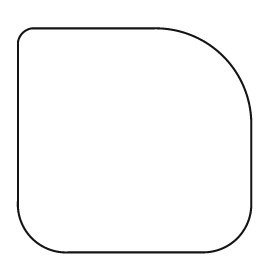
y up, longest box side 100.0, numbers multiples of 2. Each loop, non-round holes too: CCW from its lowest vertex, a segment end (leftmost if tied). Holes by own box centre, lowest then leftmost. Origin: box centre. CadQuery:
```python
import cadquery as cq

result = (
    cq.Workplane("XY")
    .moveTo(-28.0, -48.0)
    .lineTo(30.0, -48.0)
    .threePointArc((44.0, -42.0), (50.0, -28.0))
    .lineTo(50.0, 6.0)
    .threePointArc((38.0, 36.0), (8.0, 48.0))
    .lineTo(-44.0, 48.0)
    .threePointArc((-48.0, 46.0), (-50.0, 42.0))
    .lineTo(-50.0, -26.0)
    .threePointArc((-44.0, -42.0), (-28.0, -48.0))
    .close()
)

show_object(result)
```